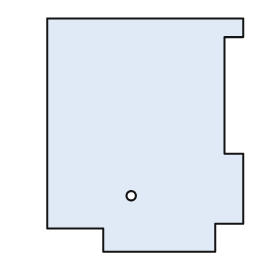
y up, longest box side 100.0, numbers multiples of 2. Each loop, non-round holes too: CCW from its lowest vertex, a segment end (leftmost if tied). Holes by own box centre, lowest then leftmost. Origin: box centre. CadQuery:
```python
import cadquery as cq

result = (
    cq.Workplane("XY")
    .moveTo(-18.0, -50.0)
    .lineTo(30.0, -50.0)
    .lineTo(30.0, -38.0)
    .lineTo(42.0, -38.0)
    .lineTo(42.0, -8.0)
    .lineTo(34.0, -8.0)
    .lineTo(34.0, 42.0)
    .lineTo(42.0, 42.0)
    .lineTo(42.0, 50.0)
    .lineTo(-42.0, 50.0)
    .lineTo(-42.0, -40.0)
    .lineTo(-18.0, -40.0)
    .close()
    .moveTo(-6.0, -26.0)
    .circle(2.0)
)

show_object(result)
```